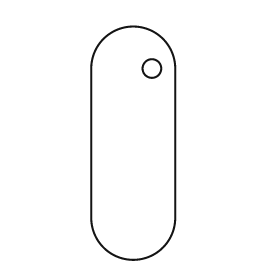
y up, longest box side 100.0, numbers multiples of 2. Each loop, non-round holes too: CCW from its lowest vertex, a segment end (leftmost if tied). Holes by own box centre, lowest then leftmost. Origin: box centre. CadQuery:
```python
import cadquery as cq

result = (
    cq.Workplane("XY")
    .moveTo(-18.0, -32.0)
    .threePointArc((0.0, -50.0), (18.0, -32.0))
    .lineTo(18.0, 32.0)
    .threePointArc((0.0, 50.0), (-18.0, 32.0))
    .close()
    .moveTo(8.0, 32.0)
    .circle(4.0)
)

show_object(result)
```